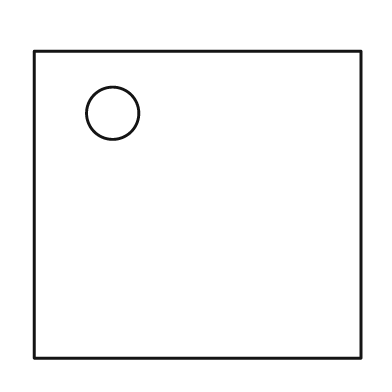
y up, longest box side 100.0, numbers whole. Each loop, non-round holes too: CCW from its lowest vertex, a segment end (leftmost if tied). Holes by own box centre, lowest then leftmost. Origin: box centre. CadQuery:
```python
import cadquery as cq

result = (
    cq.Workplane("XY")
    .moveTo(-50.0, -47.0)
    .lineTo(50.0, -47.0)
    .lineTo(50.0, 47.0)
    .lineTo(-50.0, 47.0)
    .close()
    .moveTo(-26.0, 28.0)
    .circle(8.0)
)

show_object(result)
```